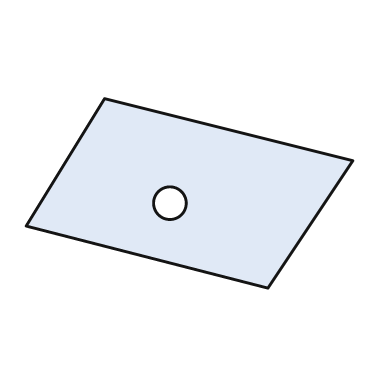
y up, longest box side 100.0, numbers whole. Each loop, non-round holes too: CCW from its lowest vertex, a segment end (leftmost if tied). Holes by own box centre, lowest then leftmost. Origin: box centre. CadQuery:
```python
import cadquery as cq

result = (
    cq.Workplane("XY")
    .moveTo(24.0, -29.0)
    .lineTo(50.0, 10.0)
    .lineTo(-26.0, 29.0)
    .lineTo(-50.0, -10.0)
    .close()
    .moveTo(-6.0, -3.0)
    .circle(5.0)
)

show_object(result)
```